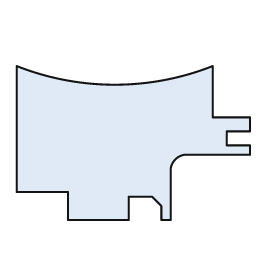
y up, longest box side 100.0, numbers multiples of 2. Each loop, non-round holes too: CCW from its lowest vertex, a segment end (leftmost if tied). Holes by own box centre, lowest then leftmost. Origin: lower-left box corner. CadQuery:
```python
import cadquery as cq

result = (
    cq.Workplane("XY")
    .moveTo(22.0, 0.0)
    .lineTo(48.0, 0.0)
    .lineTo(48.0, 10.0)
    .lineTo(58.0, 10.0)
    .lineTo(62.0, 6.0)
    .lineTo(62.0, 0.0)
    .lineTo(66.0, 0.0)
    .lineTo(66.0, 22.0)
    .threePointArc((68.0, 26.0), (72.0, 28.0))
    .lineTo(100.0, 28.0)
    .lineTo(100.0, 32.0)
    .lineTo(90.0, 32.0)
    .lineTo(90.0, 38.0)
    .lineTo(100.0, 38.0)
    .lineTo(100.0, 44.0)
    .lineTo(84.0, 44.0)
    .lineTo(84.0, 66.0)
    .threePointArc((42.0, 58.0), (0.0, 66.0))
    .lineTo(0.0, 12.0)
    .lineTo(22.0, 12.0)
    .close()
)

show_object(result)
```